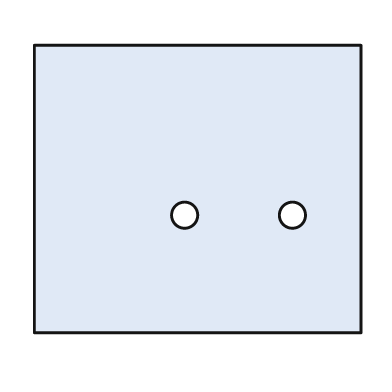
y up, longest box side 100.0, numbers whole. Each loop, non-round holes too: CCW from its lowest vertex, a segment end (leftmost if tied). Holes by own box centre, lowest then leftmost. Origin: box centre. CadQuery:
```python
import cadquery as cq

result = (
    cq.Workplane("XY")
    .moveTo(-50.0, -44.0)
    .lineTo(50.0, -44.0)
    .lineTo(50.0, 44.0)
    .lineTo(-50.0, 44.0)
    .close()
    .moveTo(-4.0, -8.0)
    .circle(4.0)
    .moveTo(29.0, -8.0)
    .circle(4.0)
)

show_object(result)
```